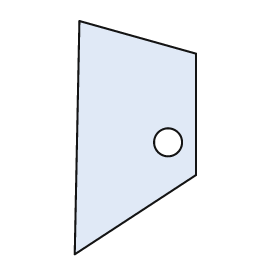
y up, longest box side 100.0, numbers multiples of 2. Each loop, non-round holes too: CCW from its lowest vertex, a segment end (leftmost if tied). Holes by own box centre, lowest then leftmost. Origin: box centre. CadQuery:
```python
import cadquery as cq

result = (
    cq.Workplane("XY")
    .moveTo(-26.0, -50.0)
    .lineTo(26.0, -16.0)
    .lineTo(26.0, 36.0)
    .lineTo(-24.0, 50.0)
    .close()
    .moveTo(14.0, -2.0)
    .circle(6.0)
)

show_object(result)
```